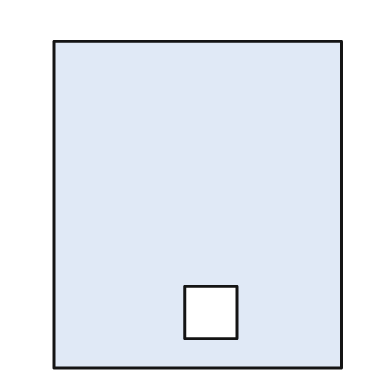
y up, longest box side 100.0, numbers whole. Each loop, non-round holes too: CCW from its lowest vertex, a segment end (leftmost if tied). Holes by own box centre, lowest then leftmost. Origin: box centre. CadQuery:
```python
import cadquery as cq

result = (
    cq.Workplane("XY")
    .moveTo(-44.0, -50.0)
    .lineTo(44.0, -50.0)
    .lineTo(44.0, 50.0)
    .lineTo(-44.0, 50.0)
    .close()
    .moveTo(-4.0, -41.0)
    .lineTo(12.0, -41.0)
    .lineTo(12.0, -25.0)
    .lineTo(-4.0, -25.0)
    .close()
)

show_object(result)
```